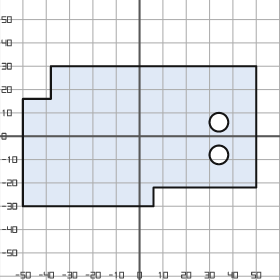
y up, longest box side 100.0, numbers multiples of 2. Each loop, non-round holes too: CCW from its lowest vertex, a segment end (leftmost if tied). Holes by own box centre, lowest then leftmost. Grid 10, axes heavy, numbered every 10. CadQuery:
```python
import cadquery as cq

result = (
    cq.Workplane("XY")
    .moveTo(-50.0, -30.0)
    .lineTo(6.0, -30.0)
    .lineTo(6.0, -22.0)
    .lineTo(50.0, -22.0)
    .lineTo(50.0, 30.0)
    .lineTo(-38.0, 30.0)
    .lineTo(-38.0, 16.0)
    .lineTo(-50.0, 16.0)
    .close()
    .moveTo(34.0, -8.0)
    .circle(4.0)
    .moveTo(34.0, 6.0)
    .circle(4.0)
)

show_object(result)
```